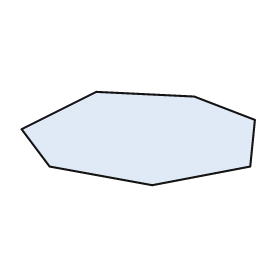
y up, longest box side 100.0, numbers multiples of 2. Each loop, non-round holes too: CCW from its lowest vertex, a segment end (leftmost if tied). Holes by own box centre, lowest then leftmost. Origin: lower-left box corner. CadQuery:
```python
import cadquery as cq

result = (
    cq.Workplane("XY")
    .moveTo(56.0, 0.0)
    .lineTo(98.0, 8.0)
    .lineTo(100.0, 28.0)
    .lineTo(74.0, 38.0)
    .lineTo(32.0, 40.0)
    .lineTo(0.0, 24.0)
    .lineTo(12.0, 8.0)
    .close()
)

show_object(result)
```